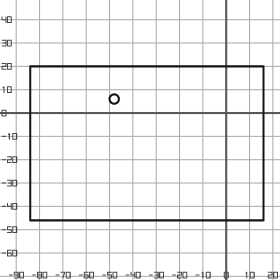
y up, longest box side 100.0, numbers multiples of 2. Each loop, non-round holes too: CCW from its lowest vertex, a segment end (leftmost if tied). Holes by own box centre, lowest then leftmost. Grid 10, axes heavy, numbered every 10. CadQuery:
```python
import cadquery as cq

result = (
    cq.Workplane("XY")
    .moveTo(-84.0, -46.0)
    .lineTo(16.0, -46.0)
    .lineTo(16.0, 20.0)
    .lineTo(-84.0, 20.0)
    .close()
    .moveTo(-48.0, 6.0)
    .circle(2.0)
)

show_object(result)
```